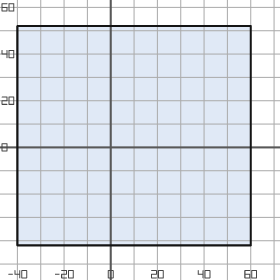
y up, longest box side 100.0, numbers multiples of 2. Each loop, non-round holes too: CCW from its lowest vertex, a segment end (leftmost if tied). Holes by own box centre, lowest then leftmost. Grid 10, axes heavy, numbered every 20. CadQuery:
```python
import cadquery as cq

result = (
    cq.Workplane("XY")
    .moveTo(-40.0, -42.0)
    .lineTo(60.0, -42.0)
    .lineTo(60.0, 52.0)
    .lineTo(-40.0, 52.0)
    .close()
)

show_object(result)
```